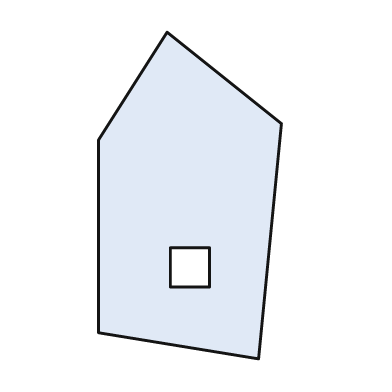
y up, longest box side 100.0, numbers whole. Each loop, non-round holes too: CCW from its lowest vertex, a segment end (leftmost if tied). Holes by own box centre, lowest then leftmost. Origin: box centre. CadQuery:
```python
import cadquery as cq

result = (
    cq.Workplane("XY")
    .moveTo(21.0, -50.0)
    .lineTo(28.0, 22.0)
    .lineTo(-7.0, 50.0)
    .lineTo(-28.0, 17.0)
    .lineTo(-28.0, -42.0)
    .close()
    .moveTo(-6.0, -28.0)
    .lineTo(6.0, -28.0)
    .lineTo(6.0, -16.0)
    .lineTo(-6.0, -16.0)
    .close()
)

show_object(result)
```